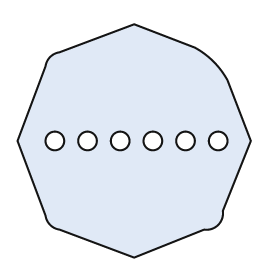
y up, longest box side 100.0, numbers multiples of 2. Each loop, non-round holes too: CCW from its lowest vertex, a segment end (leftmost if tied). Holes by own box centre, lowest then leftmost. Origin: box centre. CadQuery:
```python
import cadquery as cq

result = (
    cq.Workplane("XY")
    .moveTo(0.0, -50.0)
    .lineTo(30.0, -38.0)
    .threePointArc((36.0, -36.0), (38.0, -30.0))
    .lineTo(50.0, 0.0)
    .lineTo(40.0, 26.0)
    .threePointArc((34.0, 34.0), (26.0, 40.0))
    .lineTo(0.0, 50.0)
    .lineTo(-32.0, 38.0)
    .threePointArc((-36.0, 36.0), (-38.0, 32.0))
    .lineTo(-50.0, 0.0)
    .lineTo(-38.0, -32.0)
    .threePointArc((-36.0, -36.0), (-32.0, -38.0))
    .close()
    .moveTo(-34.0, 0.0)
    .circle(4.0)
    .moveTo(-20.0, 0.0)
    .circle(4.0)
    .moveTo(-6.0, 0.0)
    .circle(4.0)
    .moveTo(8.0, 0.0)
    .circle(4.0)
    .moveTo(22.0, 0.0)
    .circle(4.0)
    .moveTo(36.0, 0.0)
    .circle(4.0)
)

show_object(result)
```